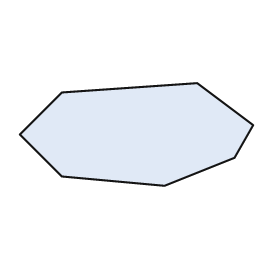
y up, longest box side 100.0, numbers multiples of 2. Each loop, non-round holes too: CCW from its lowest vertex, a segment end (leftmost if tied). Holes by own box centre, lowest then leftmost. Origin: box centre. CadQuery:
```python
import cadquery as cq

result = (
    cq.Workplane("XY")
    .moveTo(12.0, -22.0)
    .lineTo(42.0, -10.0)
    .lineTo(50.0, 4.0)
    .lineTo(26.0, 22.0)
    .lineTo(-32.0, 18.0)
    .lineTo(-50.0, 0.0)
    .lineTo(-32.0, -18.0)
    .close()
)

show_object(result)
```